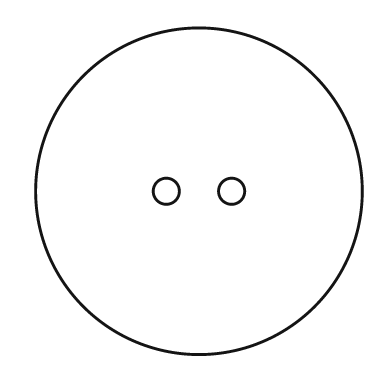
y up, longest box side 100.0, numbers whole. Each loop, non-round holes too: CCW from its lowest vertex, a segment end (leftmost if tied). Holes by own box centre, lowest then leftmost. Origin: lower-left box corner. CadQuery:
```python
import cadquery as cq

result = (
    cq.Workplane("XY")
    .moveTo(50.0, 50.0)
    .circle(50.0)
    .moveTo(40.0, 50.0)
    .circle(4.0)
    .moveTo(60.0, 50.0)
    .circle(4.0)
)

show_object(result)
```